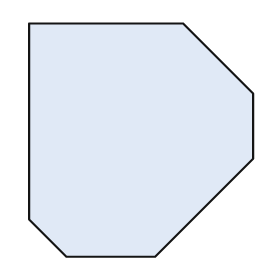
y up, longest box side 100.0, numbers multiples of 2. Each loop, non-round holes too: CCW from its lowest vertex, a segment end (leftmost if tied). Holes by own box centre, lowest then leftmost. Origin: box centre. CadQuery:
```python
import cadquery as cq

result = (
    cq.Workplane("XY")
    .moveTo(-32.0, -50.0)
    .lineTo(6.0, -50.0)
    .lineTo(48.0, -8.0)
    .lineTo(48.0, 20.0)
    .lineTo(18.0, 50.0)
    .lineTo(-48.0, 50.0)
    .lineTo(-48.0, -34.0)
    .close()
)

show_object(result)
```